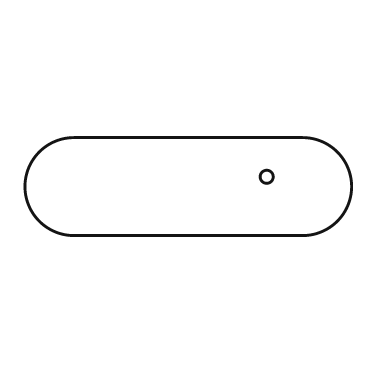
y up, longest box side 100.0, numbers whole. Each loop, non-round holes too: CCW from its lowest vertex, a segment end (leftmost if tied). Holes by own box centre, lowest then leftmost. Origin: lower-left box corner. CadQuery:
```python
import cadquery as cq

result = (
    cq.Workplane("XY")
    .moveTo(15.0, 0.0)
    .lineTo(85.0, 0.0)
    .threePointArc((100.0, 15.0), (85.0, 30.0))
    .lineTo(15.0, 30.0)
    .threePointArc((0.0, 15.0), (15.0, 0.0))
    .close()
    .moveTo(74.0, 18.0)
    .circle(2.0)
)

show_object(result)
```